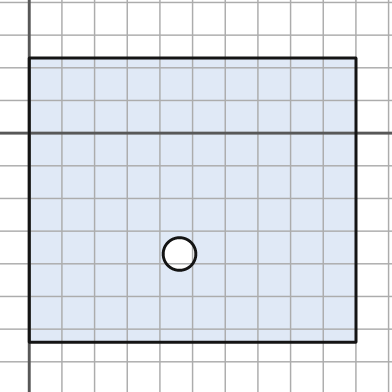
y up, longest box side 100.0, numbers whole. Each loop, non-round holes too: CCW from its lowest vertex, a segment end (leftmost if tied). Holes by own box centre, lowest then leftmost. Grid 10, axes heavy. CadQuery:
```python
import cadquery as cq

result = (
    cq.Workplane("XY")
    .moveTo(0.0, -64.0)
    .lineTo(100.0, -64.0)
    .lineTo(100.0, 23.0)
    .lineTo(0.0, 23.0)
    .close()
    .moveTo(46.0, -37.0)
    .circle(5.0)
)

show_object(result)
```